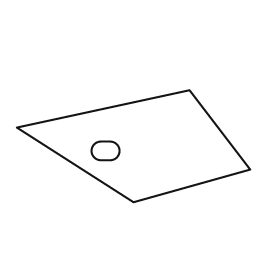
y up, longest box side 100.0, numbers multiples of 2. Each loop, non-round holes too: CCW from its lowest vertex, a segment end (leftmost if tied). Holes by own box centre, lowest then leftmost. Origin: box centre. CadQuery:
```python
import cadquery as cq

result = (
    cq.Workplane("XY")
    .moveTo(0.0, -24.0)
    .lineTo(50.0, -10.0)
    .lineTo(24.0, 24.0)
    .lineTo(-50.0, 8.0)
    .close()
    .moveTo(-14.0, -6.0)
    .lineTo(-10.0, -6.0)
    .threePointArc((-6.0, -2.0), (-10.0, 2.0))
    .lineTo(-14.0, 2.0)
    .threePointArc((-18.0, -2.0), (-14.0, -6.0))
    .close()
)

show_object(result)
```